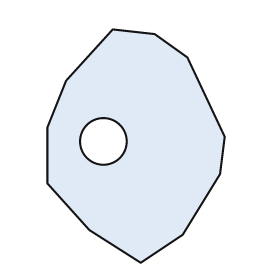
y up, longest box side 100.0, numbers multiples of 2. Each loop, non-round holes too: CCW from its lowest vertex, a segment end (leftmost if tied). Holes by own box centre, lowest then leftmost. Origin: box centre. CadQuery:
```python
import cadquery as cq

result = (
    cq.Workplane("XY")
    .moveTo(2.0, -50.0)
    .lineTo(20.0, -38.0)
    .lineTo(36.0, -12.0)
    .lineTo(38.0, 4.0)
    .lineTo(22.0, 38.0)
    .lineTo(8.0, 48.0)
    .lineTo(-10.0, 50.0)
    .lineTo(-30.0, 28.0)
    .lineTo(-38.0, 8.0)
    .lineTo(-38.0, -16.0)
    .lineTo(-20.0, -36.0)
    .close()
    .moveTo(-14.0, 2.0)
    .circle(10.0)
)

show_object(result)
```